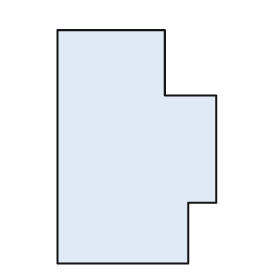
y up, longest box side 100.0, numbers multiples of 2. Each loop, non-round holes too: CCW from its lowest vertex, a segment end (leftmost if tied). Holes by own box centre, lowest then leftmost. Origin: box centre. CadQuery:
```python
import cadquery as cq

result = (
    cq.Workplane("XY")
    .moveTo(-34.0, -50.0)
    .lineTo(22.0, -50.0)
    .lineTo(22.0, -24.0)
    .lineTo(34.0, -24.0)
    .lineTo(34.0, 22.0)
    .lineTo(12.0, 22.0)
    .lineTo(12.0, 50.0)
    .lineTo(-34.0, 50.0)
    .close()
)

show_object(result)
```